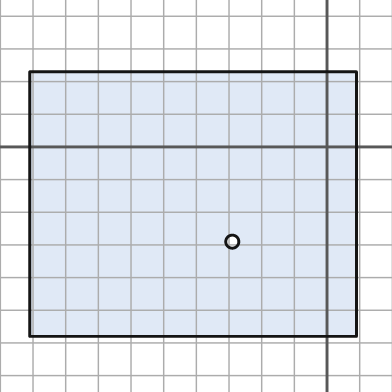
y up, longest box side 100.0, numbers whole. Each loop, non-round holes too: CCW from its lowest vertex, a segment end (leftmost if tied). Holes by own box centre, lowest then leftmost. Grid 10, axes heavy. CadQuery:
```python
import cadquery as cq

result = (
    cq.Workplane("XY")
    .moveTo(-91.0, -58.0)
    .lineTo(9.0, -58.0)
    .lineTo(9.0, 23.0)
    .lineTo(-91.0, 23.0)
    .close()
    .moveTo(-29.0, -29.0)
    .circle(2.0)
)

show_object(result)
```